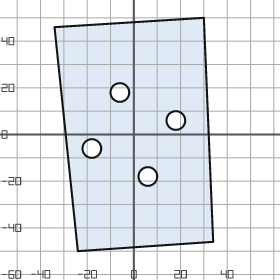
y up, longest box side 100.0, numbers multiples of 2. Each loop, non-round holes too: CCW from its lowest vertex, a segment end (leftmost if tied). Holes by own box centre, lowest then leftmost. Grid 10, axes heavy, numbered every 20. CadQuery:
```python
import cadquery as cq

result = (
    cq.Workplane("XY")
    .moveTo(-24.0, -50.0)
    .lineTo(34.0, -46.0)
    .lineTo(30.0, 50.0)
    .lineTo(-34.0, 46.0)
    .close()
    .moveTo(6.0, -18.0)
    .circle(4.0)
    .moveTo(-18.0, -6.0)
    .circle(4.0)
    .moveTo(18.0, 6.0)
    .circle(4.0)
    .moveTo(-6.0, 18.0)
    .circle(4.0)
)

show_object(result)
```